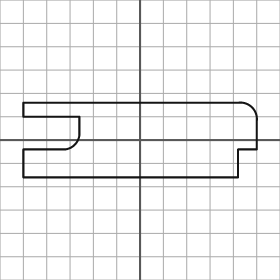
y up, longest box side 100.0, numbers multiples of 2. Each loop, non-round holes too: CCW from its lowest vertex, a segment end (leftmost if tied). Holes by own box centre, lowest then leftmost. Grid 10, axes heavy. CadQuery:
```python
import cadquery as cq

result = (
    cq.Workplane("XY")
    .moveTo(-50.0, -16.0)
    .lineTo(42.0, -16.0)
    .lineTo(42.0, -4.0)
    .lineTo(50.0, -4.0)
    .lineTo(50.0, 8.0)
    .threePointArc((48.0, 14.0), (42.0, 16.0))
    .lineTo(-50.0, 16.0)
    .lineTo(-50.0, 10.0)
    .lineTo(-26.0, 10.0)
    .lineTo(-26.0, 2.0)
    .threePointArc((-28.0, -2.0), (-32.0, -4.0))
    .lineTo(-50.0, -4.0)
    .close()
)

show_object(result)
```